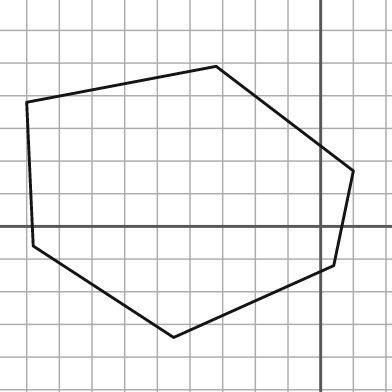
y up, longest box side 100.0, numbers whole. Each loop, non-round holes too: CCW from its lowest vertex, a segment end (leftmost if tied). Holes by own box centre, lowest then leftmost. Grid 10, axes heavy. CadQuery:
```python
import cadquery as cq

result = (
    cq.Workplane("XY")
    .moveTo(-45.0, -34.0)
    .lineTo(4.0, -12.0)
    .lineTo(10.0, 17.0)
    .lineTo(-32.0, 49.0)
    .lineTo(-90.0, 38.0)
    .lineTo(-88.0, -6.0)
    .close()
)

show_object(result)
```